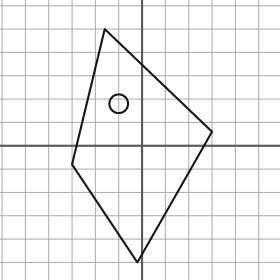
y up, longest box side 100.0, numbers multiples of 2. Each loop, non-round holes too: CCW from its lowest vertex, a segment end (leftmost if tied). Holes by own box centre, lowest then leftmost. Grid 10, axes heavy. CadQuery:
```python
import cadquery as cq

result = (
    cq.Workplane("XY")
    .moveTo(-2.0, -50.0)
    .lineTo(30.0, 6.0)
    .lineTo(-16.0, 50.0)
    .lineTo(-30.0, -8.0)
    .close()
    .moveTo(-10.0, 18.0)
    .circle(4.0)
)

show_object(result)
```